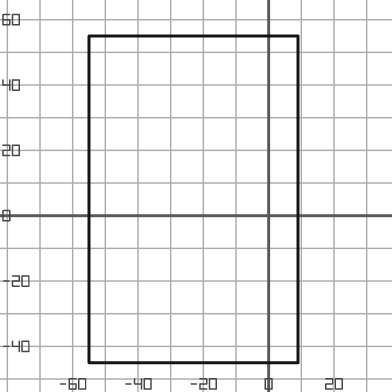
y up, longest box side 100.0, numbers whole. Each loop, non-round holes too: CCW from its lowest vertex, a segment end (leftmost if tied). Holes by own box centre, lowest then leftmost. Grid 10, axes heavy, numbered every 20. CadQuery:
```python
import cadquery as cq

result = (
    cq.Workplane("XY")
    .moveTo(-55.0, -45.0)
    .lineTo(9.0, -45.0)
    .lineTo(9.0, 55.0)
    .lineTo(-55.0, 55.0)
    .close()
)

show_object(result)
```